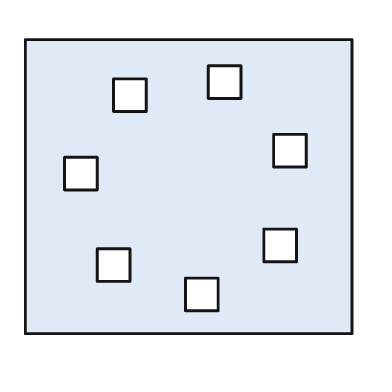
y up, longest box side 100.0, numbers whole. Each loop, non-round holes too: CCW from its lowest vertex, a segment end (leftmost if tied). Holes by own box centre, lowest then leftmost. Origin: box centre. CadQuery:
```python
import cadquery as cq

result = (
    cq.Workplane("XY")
    .moveTo(-50.0, -45.0)
    .lineTo(50.0, -45.0)
    .lineTo(50.0, 45.0)
    .lineTo(-50.0, 45.0)
    .close()
    .moveTo(-1.0, -38.0)
    .lineTo(9.0, -38.0)
    .lineTo(9.0, -28.0)
    .lineTo(-1.0, -28.0)
    .close()
    .moveTo(-28.0, -29.0)
    .lineTo(-18.0, -29.0)
    .lineTo(-18.0, -19.0)
    .lineTo(-28.0, -19.0)
    .close()
    .moveTo(23.0, -23.0)
    .lineTo(33.0, -23.0)
    .lineTo(33.0, -13.0)
    .lineTo(23.0, -13.0)
    .close()
    .moveTo(-38.0, -1.0)
    .lineTo(-28.0, -1.0)
    .lineTo(-28.0, 9.0)
    .lineTo(-38.0, 9.0)
    .close()
    .moveTo(26.0, 6.0)
    .lineTo(36.0, 6.0)
    .lineTo(36.0, 16.0)
    .lineTo(26.0, 16.0)
    .close()
    .moveTo(-23.0, 23.0)
    .lineTo(-13.0, 23.0)
    .lineTo(-13.0, 33.0)
    .lineTo(-23.0, 33.0)
    .close()
    .moveTo(6.0, 27.0)
    .lineTo(16.0, 27.0)
    .lineTo(16.0, 37.0)
    .lineTo(6.0, 37.0)
    .close()
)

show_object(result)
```